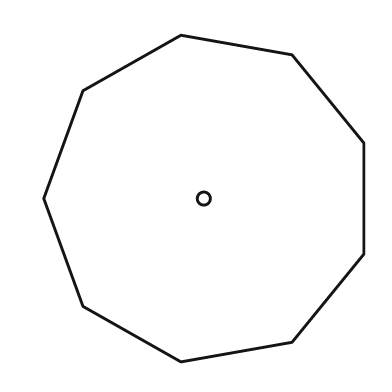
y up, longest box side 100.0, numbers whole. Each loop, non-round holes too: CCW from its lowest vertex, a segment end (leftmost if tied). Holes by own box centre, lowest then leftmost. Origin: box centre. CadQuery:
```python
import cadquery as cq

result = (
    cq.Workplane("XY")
    .moveTo(-7.0, -50.0)
    .lineTo(27.0, -44.0)
    .lineTo(49.0, -17.0)
    .lineTo(49.0, 17.0)
    .lineTo(27.0, 44.0)
    .lineTo(-7.0, 50.0)
    .lineTo(-37.0, 33.0)
    .lineTo(-49.0, 0.0)
    .lineTo(-37.0, -33.0)
    .close()
    .moveTo(0.0, 0.0)
    .circle(2.0)
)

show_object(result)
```